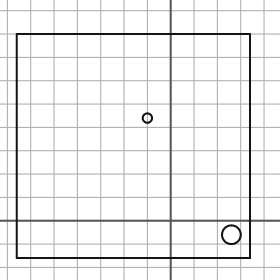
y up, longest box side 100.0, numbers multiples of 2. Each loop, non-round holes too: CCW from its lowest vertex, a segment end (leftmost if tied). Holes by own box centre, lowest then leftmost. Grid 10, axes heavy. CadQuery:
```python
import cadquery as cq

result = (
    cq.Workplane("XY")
    .moveTo(-66.0, -16.0)
    .lineTo(34.0, -16.0)
    .lineTo(34.0, 80.0)
    .lineTo(-66.0, 80.0)
    .close()
    .moveTo(26.0, -6.0)
    .circle(4.0)
    .moveTo(-10.0, 44.0)
    .circle(2.0)
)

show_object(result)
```